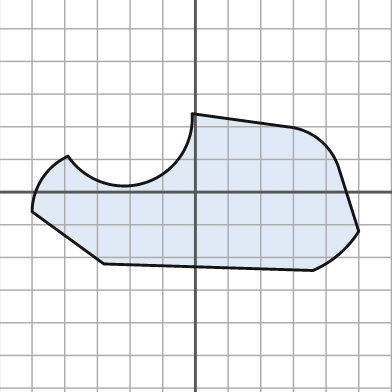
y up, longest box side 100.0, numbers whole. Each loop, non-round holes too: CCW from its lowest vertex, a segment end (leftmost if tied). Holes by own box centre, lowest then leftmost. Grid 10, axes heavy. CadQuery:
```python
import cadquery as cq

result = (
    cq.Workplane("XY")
    .moveTo(36.0, -24.0)
    .threePointArc((44.0, -19.0), (50.0, -12.0))
    .lineTo(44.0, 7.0)
    .threePointArc((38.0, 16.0), (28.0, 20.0))
    .lineTo(-1.0, 24.0)
    .threePointArc((-15.0, 3.0), (-39.0, 11.0))
    .threePointArc((-47.0, 4.0), (-50.0, -6.0))
    .lineTo(-28.0, -22.0)
    .close()
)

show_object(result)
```